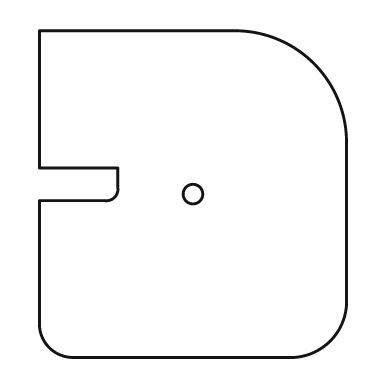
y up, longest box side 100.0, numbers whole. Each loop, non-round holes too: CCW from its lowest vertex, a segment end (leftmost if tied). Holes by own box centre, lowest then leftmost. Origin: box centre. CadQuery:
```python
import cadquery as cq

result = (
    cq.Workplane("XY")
    .moveTo(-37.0, -50.0)
    .lineTo(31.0, -50.0)
    .threePointArc((42.0, -45.0), (47.0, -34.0))
    .lineTo(47.0, 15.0)
    .threePointArc((37.0, 40.0), (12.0, 50.0))
    .lineTo(-47.0, 50.0)
    .lineTo(-47.0, 8.0)
    .lineTo(-23.0, 8.0)
    .lineTo(-23.0, 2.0)
    .threePointArc((-24.0, -1.0), (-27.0, -2.0))
    .lineTo(-47.0, -2.0)
    .lineTo(-47.0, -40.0)
    .threePointArc((-44.0, -47.0), (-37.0, -50.0))
    .close()
    .moveTo(0.0, 0.0)
    .circle(3.0)
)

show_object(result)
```